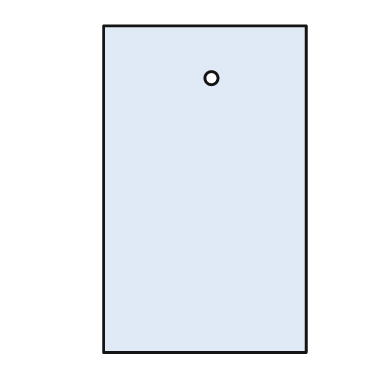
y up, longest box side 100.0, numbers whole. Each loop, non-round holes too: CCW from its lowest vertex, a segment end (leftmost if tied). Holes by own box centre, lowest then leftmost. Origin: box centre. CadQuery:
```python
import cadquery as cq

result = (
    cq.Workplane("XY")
    .moveTo(-31.0, -50.0)
    .lineTo(31.0, -50.0)
    .lineTo(31.0, 50.0)
    .lineTo(-31.0, 50.0)
    .close()
    .moveTo(2.0, 34.0)
    .circle(2.0)
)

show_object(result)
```